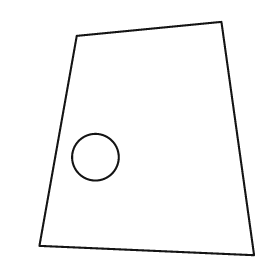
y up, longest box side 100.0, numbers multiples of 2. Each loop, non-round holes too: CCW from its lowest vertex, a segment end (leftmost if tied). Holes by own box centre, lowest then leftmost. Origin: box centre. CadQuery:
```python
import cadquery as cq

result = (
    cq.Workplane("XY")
    .moveTo(46.0, -50.0)
    .lineTo(32.0, 50.0)
    .lineTo(-30.0, 44.0)
    .lineTo(-46.0, -46.0)
    .close()
    .moveTo(-22.0, -8.0)
    .circle(10.0)
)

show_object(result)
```